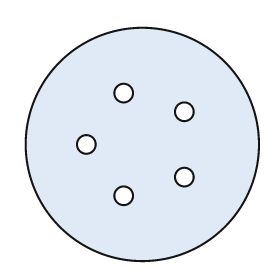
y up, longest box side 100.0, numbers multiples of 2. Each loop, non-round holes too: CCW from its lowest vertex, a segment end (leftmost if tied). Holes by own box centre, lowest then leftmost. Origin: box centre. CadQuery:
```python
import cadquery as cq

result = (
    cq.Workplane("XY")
    .moveTo(0.0, 0.0)
    .circle(50.0)
    .moveTo(-8.0, -22.0)
    .circle(4.0)
    .moveTo(18.0, -14.0)
    .circle(4.0)
    .moveTo(-24.0, 0.0)
    .circle(4.0)
    .moveTo(18.0, 14.0)
    .circle(4.0)
    .moveTo(-8.0, 22.0)
    .circle(4.0)
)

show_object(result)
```